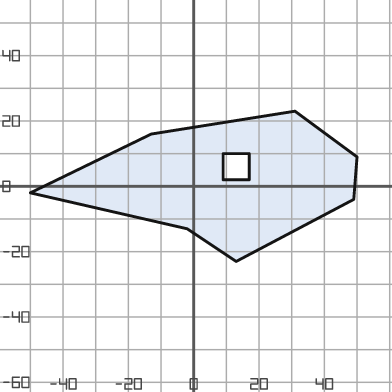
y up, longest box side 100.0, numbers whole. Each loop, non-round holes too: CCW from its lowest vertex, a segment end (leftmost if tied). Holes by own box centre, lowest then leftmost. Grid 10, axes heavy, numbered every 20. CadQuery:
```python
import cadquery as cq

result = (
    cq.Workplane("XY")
    .moveTo(13.0, -23.0)
    .lineTo(49.0, -4.0)
    .lineTo(50.0, 9.0)
    .lineTo(31.0, 23.0)
    .lineTo(-13.0, 16.0)
    .lineTo(-50.0, -2.0)
    .lineTo(-2.0, -13.0)
    .close()
    .moveTo(9.0, 2.0)
    .lineTo(17.0, 2.0)
    .lineTo(17.0, 10.0)
    .lineTo(9.0, 10.0)
    .close()
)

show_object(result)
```